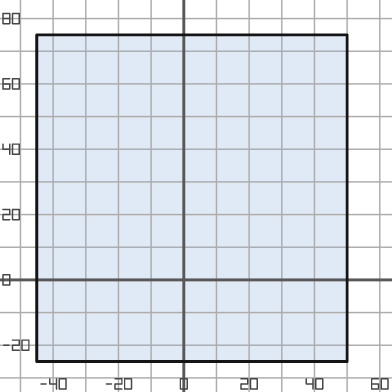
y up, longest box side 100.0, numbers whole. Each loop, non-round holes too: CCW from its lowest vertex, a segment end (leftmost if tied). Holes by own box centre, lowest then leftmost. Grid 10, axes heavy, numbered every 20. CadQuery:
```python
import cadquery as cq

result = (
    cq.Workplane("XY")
    .moveTo(-45.0, -25.0)
    .lineTo(50.0, -25.0)
    .lineTo(50.0, 75.0)
    .lineTo(-45.0, 75.0)
    .close()
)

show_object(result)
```